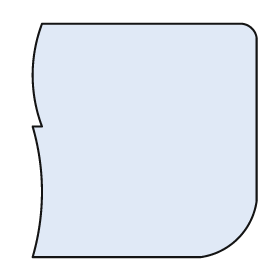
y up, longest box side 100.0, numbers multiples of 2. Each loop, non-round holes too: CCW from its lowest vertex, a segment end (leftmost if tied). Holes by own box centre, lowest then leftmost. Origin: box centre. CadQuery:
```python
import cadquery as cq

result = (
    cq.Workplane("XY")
    .moveTo(-48.0, -50.0)
    .lineTo(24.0, -50.0)
    .threePointArc((40.0, -42.0), (48.0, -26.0))
    .lineTo(48.0, 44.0)
    .threePointArc((46.0, 48.0), (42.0, 50.0))
    .lineTo(-44.0, 50.0)
    .threePointArc((-48.0, 28.0), (-44.0, 6.0))
    .lineTo(-48.0, 6.0)
    .threePointArc((-44.0, -22.0), (-48.0, -50.0))
    .close()
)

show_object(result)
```